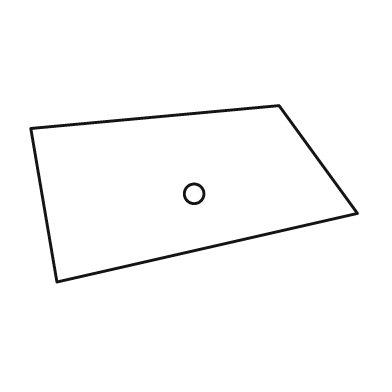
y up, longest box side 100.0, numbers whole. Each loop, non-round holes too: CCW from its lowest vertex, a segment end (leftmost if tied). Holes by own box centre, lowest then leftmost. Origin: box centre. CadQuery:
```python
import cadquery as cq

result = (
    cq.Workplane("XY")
    .moveTo(-42.0, -27.0)
    .lineTo(50.0, -6.0)
    .lineTo(26.0, 27.0)
    .lineTo(-50.0, 20.0)
    .close()
    .moveTo(0.0, 0.0)
    .circle(3.0)
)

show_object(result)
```